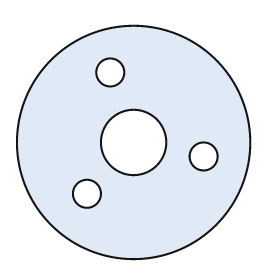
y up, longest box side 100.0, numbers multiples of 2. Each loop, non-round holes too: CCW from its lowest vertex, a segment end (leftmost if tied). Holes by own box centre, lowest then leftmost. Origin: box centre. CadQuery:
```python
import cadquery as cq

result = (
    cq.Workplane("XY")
    .moveTo(0.0, 0.0)
    .circle(50.0)
    .moveTo(-20.0, -22.0)
    .circle(6.0)
    .moveTo(30.0, -6.0)
    .circle(6.0)
    .moveTo(0.0, 0.0)
    .circle(14.0)
    .moveTo(-10.0, 30.0)
    .circle(6.0)
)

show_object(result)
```